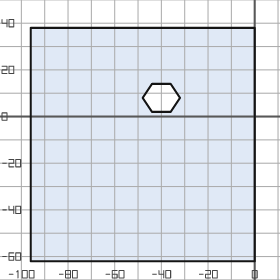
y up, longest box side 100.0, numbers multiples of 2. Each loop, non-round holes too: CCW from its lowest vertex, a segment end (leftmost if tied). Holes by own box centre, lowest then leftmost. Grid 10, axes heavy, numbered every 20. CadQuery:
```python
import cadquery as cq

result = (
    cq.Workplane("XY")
    .moveTo(-96.0, -62.0)
    .lineTo(0.0, -62.0)
    .lineTo(0.0, 38.0)
    .lineTo(-96.0, 38.0)
    .close()
    .moveTo(-44.0, 2.0)
    .lineTo(-36.0, 2.0)
    .lineTo(-32.0, 8.0)
    .lineTo(-36.0, 14.0)
    .lineTo(-44.0, 14.0)
    .lineTo(-48.0, 8.0)
    .close()
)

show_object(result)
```